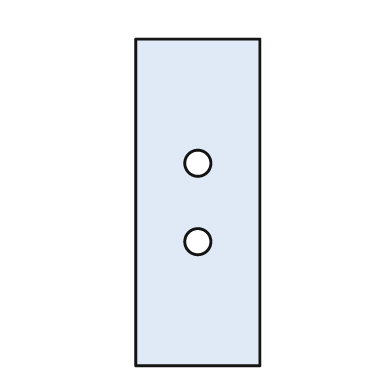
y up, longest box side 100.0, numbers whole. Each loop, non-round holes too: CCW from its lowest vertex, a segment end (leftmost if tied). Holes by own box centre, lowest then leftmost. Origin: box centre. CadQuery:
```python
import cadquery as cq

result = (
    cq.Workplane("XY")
    .moveTo(-19.0, -50.0)
    .lineTo(19.0, -50.0)
    .lineTo(19.0, 50.0)
    .lineTo(-19.0, 50.0)
    .close()
    .moveTo(0.0, -12.0)
    .circle(4.0)
    .moveTo(0.0, 12.0)
    .circle(4.0)
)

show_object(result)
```